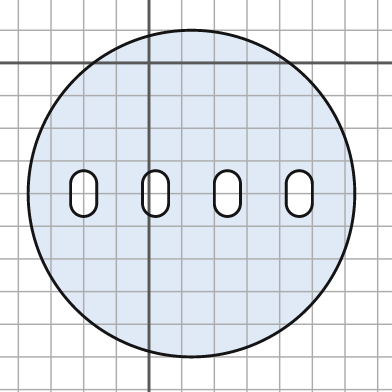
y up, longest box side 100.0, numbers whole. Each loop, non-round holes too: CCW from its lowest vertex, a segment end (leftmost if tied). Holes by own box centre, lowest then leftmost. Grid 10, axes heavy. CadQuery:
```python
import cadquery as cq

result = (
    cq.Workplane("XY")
    .moveTo(13.0, -40.0)
    .circle(50.0)
    .moveTo(-24.0, -43.0)
    .threePointArc((-20.0, -47.0), (-16.0, -43.0))
    .lineTo(-16.0, -37.0)
    .threePointArc((-20.0, -33.0), (-24.0, -37.0))
    .close()
    .moveTo(-2.0, -43.0)
    .threePointArc((2.0, -47.0), (6.0, -43.0))
    .lineTo(6.0, -37.0)
    .threePointArc((2.0, -33.0), (-2.0, -37.0))
    .close()
    .moveTo(20.0, -43.0)
    .threePointArc((24.0, -47.0), (28.0, -43.0))
    .lineTo(28.0, -37.0)
    .threePointArc((24.0, -33.0), (20.0, -37.0))
    .close()
    .moveTo(42.0, -43.0)
    .threePointArc((46.0, -47.0), (50.0, -43.0))
    .lineTo(50.0, -37.0)
    .threePointArc((46.0, -33.0), (42.0, -37.0))
    .close()
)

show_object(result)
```